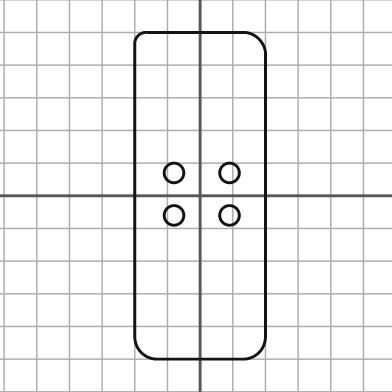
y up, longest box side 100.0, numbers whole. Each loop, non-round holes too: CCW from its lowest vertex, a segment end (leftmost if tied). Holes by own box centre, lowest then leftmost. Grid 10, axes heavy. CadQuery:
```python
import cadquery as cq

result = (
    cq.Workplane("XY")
    .moveTo(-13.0, -50.0)
    .lineTo(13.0, -50.0)
    .threePointArc((18.0, -48.0), (20.0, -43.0))
    .lineTo(20.0, 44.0)
    .threePointArc((18.0, 48.0), (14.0, 50.0))
    .lineTo(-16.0, 50.0)
    .threePointArc((-19.0, 49.0), (-20.0, 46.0))
    .lineTo(-20.0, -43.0)
    .threePointArc((-18.0, -48.0), (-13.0, -50.0))
    .close()
    .moveTo(-8.0, -6.0)
    .circle(3.0)
    .moveTo(9.0, -6.0)
    .circle(3.0)
    .moveTo(-8.0, 7.0)
    .circle(3.0)
    .moveTo(9.0, 7.0)
    .circle(3.0)
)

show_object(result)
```